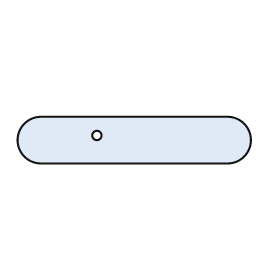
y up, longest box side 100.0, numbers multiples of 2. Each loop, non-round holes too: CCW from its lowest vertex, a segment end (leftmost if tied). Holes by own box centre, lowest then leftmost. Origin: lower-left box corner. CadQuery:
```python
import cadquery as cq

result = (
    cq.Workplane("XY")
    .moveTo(10.0, 0.0)
    .lineTo(90.0, 0.0)
    .threePointArc((100.0, 10.0), (90.0, 20.0))
    .lineTo(10.0, 20.0)
    .threePointArc((0.0, 10.0), (10.0, 0.0))
    .close()
    .moveTo(34.0, 12.0)
    .circle(2.0)
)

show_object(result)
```